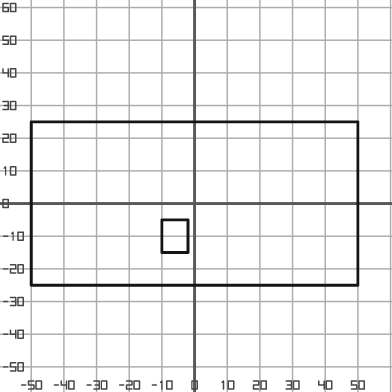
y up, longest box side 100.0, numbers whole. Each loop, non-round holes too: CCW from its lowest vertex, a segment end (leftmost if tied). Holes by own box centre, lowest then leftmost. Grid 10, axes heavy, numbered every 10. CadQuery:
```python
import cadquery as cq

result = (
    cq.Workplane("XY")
    .moveTo(-50.0, -25.0)
    .lineTo(50.0, -25.0)
    .lineTo(50.0, 25.0)
    .lineTo(-50.0, 25.0)
    .close()
    .moveTo(-10.0, -15.0)
    .lineTo(-2.0, -15.0)
    .lineTo(-2.0, -5.0)
    .lineTo(-10.0, -5.0)
    .close()
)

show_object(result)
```